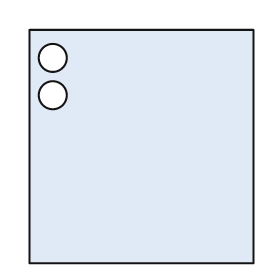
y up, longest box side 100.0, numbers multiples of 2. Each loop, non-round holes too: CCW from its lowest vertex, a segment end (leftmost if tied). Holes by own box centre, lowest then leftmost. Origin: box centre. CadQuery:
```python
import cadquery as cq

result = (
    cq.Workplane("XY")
    .moveTo(-48.0, -50.0)
    .lineTo(48.0, -50.0)
    .lineTo(48.0, 50.0)
    .lineTo(-48.0, 50.0)
    .close()
    .moveTo(-38.0, 22.0)
    .circle(6.0)
    .moveTo(-38.0, 38.0)
    .circle(6.0)
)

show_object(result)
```